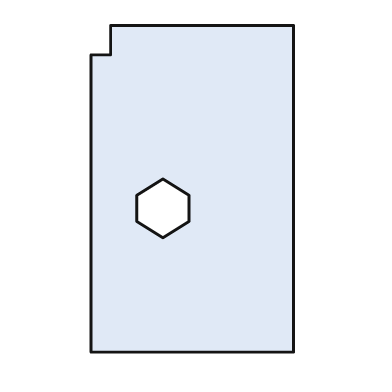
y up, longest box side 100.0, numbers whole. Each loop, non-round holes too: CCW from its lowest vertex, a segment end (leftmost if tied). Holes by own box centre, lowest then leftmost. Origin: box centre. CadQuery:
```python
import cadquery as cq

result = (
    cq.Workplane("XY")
    .moveTo(-31.0, -50.0)
    .lineTo(31.0, -50.0)
    .lineTo(31.0, 50.0)
    .lineTo(-25.0, 50.0)
    .lineTo(-25.0, 41.0)
    .lineTo(-31.0, 41.0)
    .close()
    .moveTo(-9.0, -15.0)
    .lineTo(-1.0, -10.0)
    .lineTo(-1.0, -2.0)
    .lineTo(-9.0, 3.0)
    .lineTo(-17.0, -2.0)
    .lineTo(-17.0, -10.0)
    .close()
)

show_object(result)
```